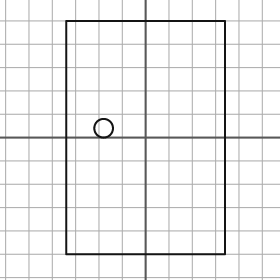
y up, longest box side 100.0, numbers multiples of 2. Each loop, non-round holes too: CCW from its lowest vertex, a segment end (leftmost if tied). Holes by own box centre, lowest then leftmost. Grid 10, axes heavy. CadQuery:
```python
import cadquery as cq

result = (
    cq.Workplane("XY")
    .moveTo(-34.0, -50.0)
    .lineTo(34.0, -50.0)
    .lineTo(34.0, 50.0)
    .lineTo(-34.0, 50.0)
    .close()
    .moveTo(-18.0, 4.0)
    .circle(4.0)
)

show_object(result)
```